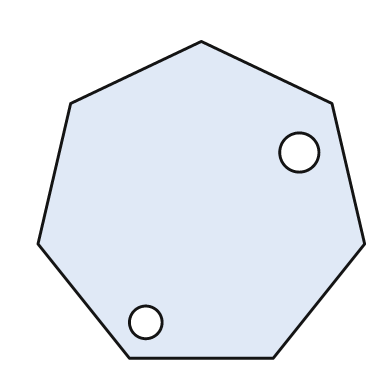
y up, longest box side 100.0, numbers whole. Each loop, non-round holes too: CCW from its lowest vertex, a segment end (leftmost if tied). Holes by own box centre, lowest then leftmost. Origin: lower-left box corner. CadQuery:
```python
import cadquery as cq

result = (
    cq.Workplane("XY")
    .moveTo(28.0, 0.0)
    .lineTo(72.0, 0.0)
    .lineTo(100.0, 35.0)
    .lineTo(90.0, 78.0)
    .lineTo(50.0, 97.0)
    .lineTo(10.0, 78.0)
    .lineTo(0.0, 35.0)
    .close()
    .moveTo(33.0, 11.0)
    .circle(5.0)
    .moveTo(80.0, 63.0)
    .circle(6.0)
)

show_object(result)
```